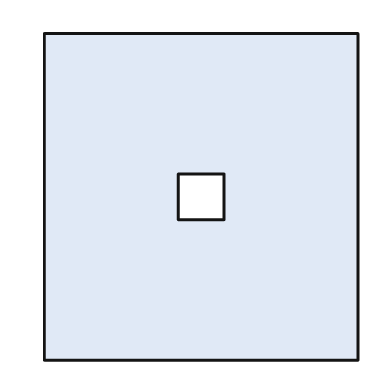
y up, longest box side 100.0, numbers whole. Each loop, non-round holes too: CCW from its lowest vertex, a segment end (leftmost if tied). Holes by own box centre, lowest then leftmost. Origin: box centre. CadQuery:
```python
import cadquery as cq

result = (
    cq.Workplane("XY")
    .moveTo(-48.0, -50.0)
    .lineTo(48.0, -50.0)
    .lineTo(48.0, 50.0)
    .lineTo(-48.0, 50.0)
    .close()
    .moveTo(-7.0, -7.0)
    .lineTo(7.0, -7.0)
    .lineTo(7.0, 7.0)
    .lineTo(-7.0, 7.0)
    .close()
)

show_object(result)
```